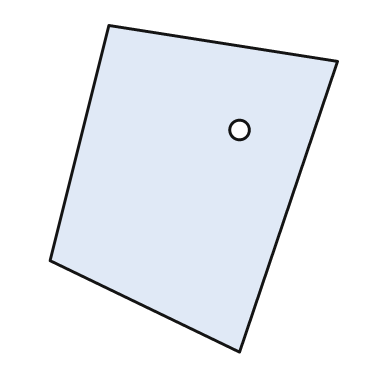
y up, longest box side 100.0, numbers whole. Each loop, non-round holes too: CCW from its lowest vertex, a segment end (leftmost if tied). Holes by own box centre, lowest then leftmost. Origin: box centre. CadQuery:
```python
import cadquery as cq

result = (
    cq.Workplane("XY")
    .moveTo(14.0, -50.0)
    .lineTo(44.0, 39.0)
    .lineTo(-26.0, 50.0)
    .lineTo(-44.0, -22.0)
    .close()
    .moveTo(14.0, 18.0)
    .circle(3.0)
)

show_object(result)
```